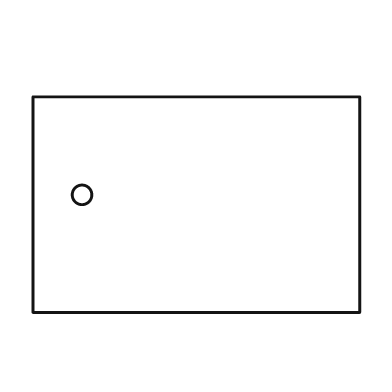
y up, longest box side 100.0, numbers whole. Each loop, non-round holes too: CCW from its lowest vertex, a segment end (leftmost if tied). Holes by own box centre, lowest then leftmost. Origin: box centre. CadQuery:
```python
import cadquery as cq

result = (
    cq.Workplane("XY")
    .moveTo(-50.0, -33.0)
    .lineTo(50.0, -33.0)
    .lineTo(50.0, 33.0)
    .lineTo(-50.0, 33.0)
    .close()
    .moveTo(-35.0, 3.0)
    .circle(3.0)
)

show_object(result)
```